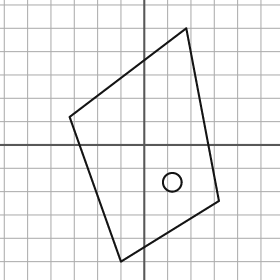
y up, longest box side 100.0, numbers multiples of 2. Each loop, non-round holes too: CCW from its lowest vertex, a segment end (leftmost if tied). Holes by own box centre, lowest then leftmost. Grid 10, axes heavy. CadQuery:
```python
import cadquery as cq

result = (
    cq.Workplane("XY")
    .moveTo(-10.0, -50.0)
    .lineTo(32.0, -24.0)
    .lineTo(18.0, 50.0)
    .lineTo(-32.0, 12.0)
    .close()
    .moveTo(12.0, -16.0)
    .circle(4.0)
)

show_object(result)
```